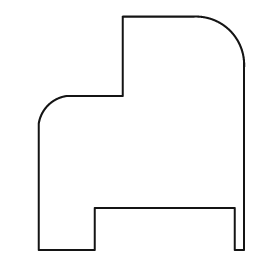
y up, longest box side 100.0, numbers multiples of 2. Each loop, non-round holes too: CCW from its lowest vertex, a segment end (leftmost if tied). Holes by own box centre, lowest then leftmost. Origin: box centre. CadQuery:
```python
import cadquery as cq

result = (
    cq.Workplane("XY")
    .moveTo(-44.0, -50.0)
    .lineTo(-20.0, -50.0)
    .lineTo(-20.0, -32.0)
    .lineTo(40.0, -32.0)
    .lineTo(40.0, -50.0)
    .lineTo(44.0, -50.0)
    .lineTo(44.0, 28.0)
    .threePointArc((38.0, 44.0), (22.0, 50.0))
    .lineTo(-8.0, 50.0)
    .lineTo(-8.0, 16.0)
    .lineTo(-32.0, 16.0)
    .threePointArc((-40.0, 12.0), (-44.0, 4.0))
    .close()
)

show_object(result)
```